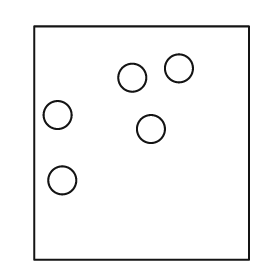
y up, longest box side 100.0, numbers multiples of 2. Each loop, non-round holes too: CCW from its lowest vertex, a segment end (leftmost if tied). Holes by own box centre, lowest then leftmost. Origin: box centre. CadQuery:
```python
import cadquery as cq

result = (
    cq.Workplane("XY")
    .moveTo(-46.0, -50.0)
    .lineTo(46.0, -50.0)
    .lineTo(46.0, 50.0)
    .lineTo(-46.0, 50.0)
    .close()
    .moveTo(-34.0, -16.0)
    .circle(6.0)
    .moveTo(4.0, 6.0)
    .circle(6.0)
    .moveTo(-36.0, 12.0)
    .circle(6.0)
    .moveTo(-4.0, 28.0)
    .circle(6.0)
    .moveTo(16.0, 32.0)
    .circle(6.0)
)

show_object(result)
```